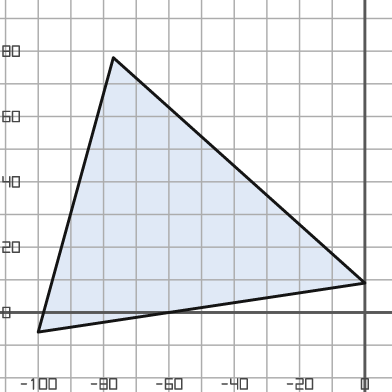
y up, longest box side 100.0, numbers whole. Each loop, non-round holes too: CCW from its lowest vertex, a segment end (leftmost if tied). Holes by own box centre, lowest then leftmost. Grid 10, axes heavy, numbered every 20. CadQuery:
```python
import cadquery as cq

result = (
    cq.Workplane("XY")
    .moveTo(-100.0, -6.0)
    .lineTo(0.0, 9.0)
    .lineTo(-77.0, 78.0)
    .close()
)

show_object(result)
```